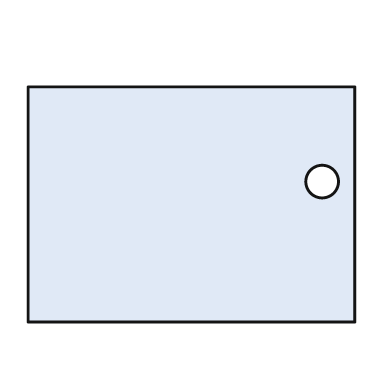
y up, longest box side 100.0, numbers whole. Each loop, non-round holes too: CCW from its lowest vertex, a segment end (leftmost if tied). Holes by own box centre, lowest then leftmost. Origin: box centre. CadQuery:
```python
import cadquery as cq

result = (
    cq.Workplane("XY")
    .moveTo(-50.0, -36.0)
    .lineTo(50.0, -36.0)
    .lineTo(50.0, 36.0)
    .lineTo(-50.0, 36.0)
    .close()
    .moveTo(40.0, 7.0)
    .circle(5.0)
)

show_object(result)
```